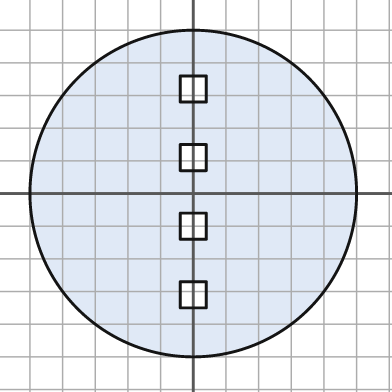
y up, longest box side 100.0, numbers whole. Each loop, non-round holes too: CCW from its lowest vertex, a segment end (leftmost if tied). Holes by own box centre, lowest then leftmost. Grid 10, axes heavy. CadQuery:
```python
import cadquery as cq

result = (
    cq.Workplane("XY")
    .moveTo(0.0, 0.0)
    .circle(50.0)
    .moveTo(-4.0, -35.0)
    .lineTo(4.0, -35.0)
    .lineTo(4.0, -27.0)
    .lineTo(-4.0, -27.0)
    .close()
    .moveTo(-4.0, -14.0)
    .lineTo(4.0, -14.0)
    .lineTo(4.0, -6.0)
    .lineTo(-4.0, -6.0)
    .close()
    .moveTo(-4.0, 7.0)
    .lineTo(4.0, 7.0)
    .lineTo(4.0, 15.0)
    .lineTo(-4.0, 15.0)
    .close()
    .moveTo(-4.0, 28.0)
    .lineTo(4.0, 28.0)
    .lineTo(4.0, 36.0)
    .lineTo(-4.0, 36.0)
    .close()
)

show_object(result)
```